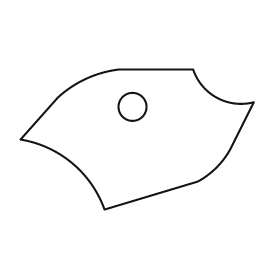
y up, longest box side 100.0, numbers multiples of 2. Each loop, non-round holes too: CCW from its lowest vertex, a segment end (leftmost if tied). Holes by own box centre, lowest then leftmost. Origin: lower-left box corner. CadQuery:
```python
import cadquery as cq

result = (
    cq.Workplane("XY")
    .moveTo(36.0, 0.0)
    .lineTo(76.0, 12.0)
    .threePointArc((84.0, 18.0), (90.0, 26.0))
    .lineTo(100.0, 46.0)
    .threePointArc((84.0, 48.0), (74.0, 60.0))
    .lineTo(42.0, 60.0)
    .threePointArc((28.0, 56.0), (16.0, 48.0))
    .lineTo(0.0, 30.0)
    .threePointArc((22.0, 20.0), (36.0, 0.0))
    .close()
    .moveTo(48.0, 44.0)
    .circle(6.0)
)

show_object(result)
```